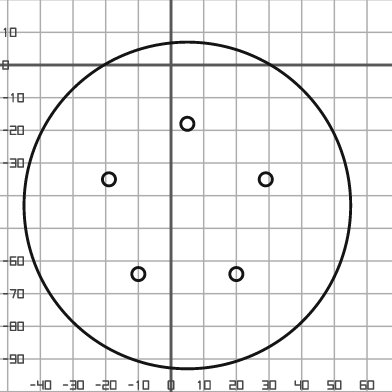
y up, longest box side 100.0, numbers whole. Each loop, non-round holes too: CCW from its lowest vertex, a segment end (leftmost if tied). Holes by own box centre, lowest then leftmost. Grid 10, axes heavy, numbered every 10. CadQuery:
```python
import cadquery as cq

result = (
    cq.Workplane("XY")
    .moveTo(5.0, -43.0)
    .circle(50.0)
    .moveTo(-10.0, -64.0)
    .circle(2.0)
    .moveTo(20.0, -64.0)
    .circle(2.0)
    .moveTo(-19.0, -35.0)
    .circle(2.0)
    .moveTo(29.0, -35.0)
    .circle(2.0)
    .moveTo(5.0, -18.0)
    .circle(2.0)
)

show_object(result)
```